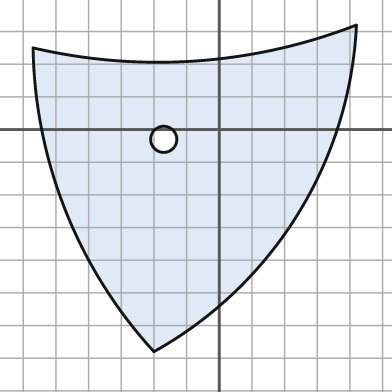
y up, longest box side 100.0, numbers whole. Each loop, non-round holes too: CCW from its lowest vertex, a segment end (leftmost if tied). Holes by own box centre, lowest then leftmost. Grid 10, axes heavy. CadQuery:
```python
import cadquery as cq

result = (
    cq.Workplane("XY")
    .moveTo(-20.0, -68.0)
    .threePointArc((24.0, -26.0), (42.0, 32.0))
    .threePointArc((-7.0, 21.0), (-57.0, 25.0))
    .threePointArc((-47.0, -25.0), (-20.0, -68.0))
    .close()
    .moveTo(-17.0, -3.0)
    .circle(4.0)
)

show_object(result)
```